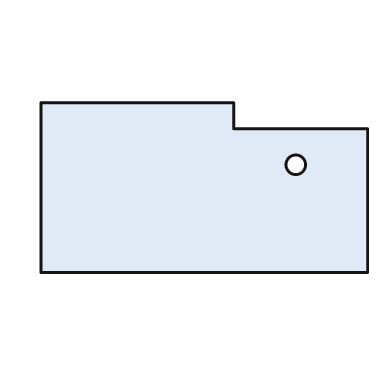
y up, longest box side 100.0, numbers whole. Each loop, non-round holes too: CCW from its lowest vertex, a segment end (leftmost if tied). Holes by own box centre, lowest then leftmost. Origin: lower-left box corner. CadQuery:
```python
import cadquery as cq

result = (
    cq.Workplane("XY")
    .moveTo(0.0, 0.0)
    .lineTo(100.0, 0.0)
    .lineTo(100.0, 44.0)
    .lineTo(59.0, 44.0)
    .lineTo(59.0, 52.0)
    .lineTo(0.0, 52.0)
    .close()
    .moveTo(78.0, 33.0)
    .circle(3.0)
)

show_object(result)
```